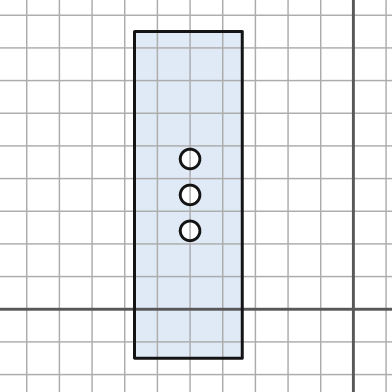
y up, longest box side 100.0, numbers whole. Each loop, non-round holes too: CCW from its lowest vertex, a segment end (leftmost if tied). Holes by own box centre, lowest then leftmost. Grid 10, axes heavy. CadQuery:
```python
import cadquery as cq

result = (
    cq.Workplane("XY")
    .moveTo(-67.0, -15.0)
    .lineTo(-34.0, -15.0)
    .lineTo(-34.0, 85.0)
    .lineTo(-67.0, 85.0)
    .close()
    .moveTo(-50.0, 24.0)
    .circle(3.0)
    .moveTo(-50.0, 35.0)
    .circle(3.0)
    .moveTo(-50.0, 46.0)
    .circle(3.0)
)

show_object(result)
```